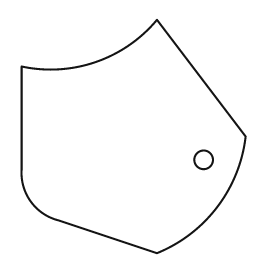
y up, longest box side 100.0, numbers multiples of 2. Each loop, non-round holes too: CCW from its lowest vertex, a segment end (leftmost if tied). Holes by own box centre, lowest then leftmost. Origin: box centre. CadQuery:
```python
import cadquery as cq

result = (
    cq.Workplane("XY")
    .moveTo(10.0, -50.0)
    .threePointArc((36.0, -30.0), (48.0, 0.0))
    .lineTo(10.0, 50.0)
    .threePointArc((-16.0, 32.0), (-48.0, 30.0))
    .lineTo(-48.0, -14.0)
    .threePointArc((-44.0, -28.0), (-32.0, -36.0))
    .close()
    .moveTo(30.0, -10.0)
    .circle(4.0)
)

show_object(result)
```